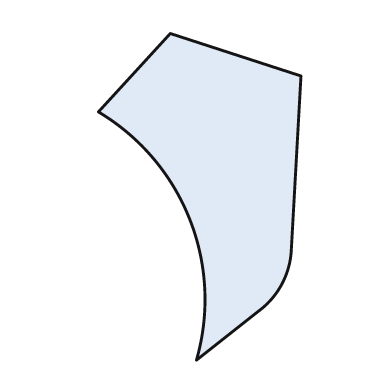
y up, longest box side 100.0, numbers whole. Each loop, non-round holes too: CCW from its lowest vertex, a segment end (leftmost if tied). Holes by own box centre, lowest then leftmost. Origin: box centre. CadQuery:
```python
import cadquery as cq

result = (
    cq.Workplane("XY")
    .moveTo(-1.0, -50.0)
    .lineTo(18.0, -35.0)
    .threePointArc((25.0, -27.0), (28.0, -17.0))
    .lineTo(31.0, 37.0)
    .lineTo(-9.0, 50.0)
    .lineTo(-31.0, 26.0)
    .threePointArc((-3.0, -7.0), (-1.0, -50.0))
    .close()
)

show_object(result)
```